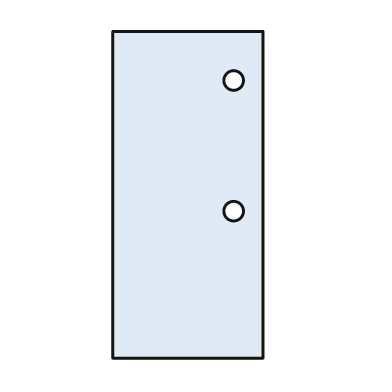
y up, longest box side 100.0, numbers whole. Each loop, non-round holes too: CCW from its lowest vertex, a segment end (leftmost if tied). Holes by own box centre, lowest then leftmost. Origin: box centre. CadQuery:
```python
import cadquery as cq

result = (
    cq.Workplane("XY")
    .moveTo(-23.0, -50.0)
    .lineTo(23.0, -50.0)
    .lineTo(23.0, 50.0)
    .lineTo(-23.0, 50.0)
    .close()
    .moveTo(14.0, -5.0)
    .circle(3.0)
    .moveTo(14.0, 35.0)
    .circle(3.0)
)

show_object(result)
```